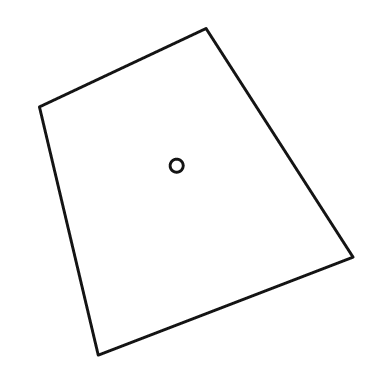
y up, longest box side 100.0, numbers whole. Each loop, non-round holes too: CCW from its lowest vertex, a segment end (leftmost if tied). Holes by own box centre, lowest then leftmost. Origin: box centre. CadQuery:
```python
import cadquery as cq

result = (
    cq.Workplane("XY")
    .moveTo(-30.0, -50.0)
    .lineTo(48.0, -20.0)
    .lineTo(3.0, 50.0)
    .lineTo(-48.0, 26.0)
    .close()
    .moveTo(-6.0, 8.0)
    .circle(2.0)
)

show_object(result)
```